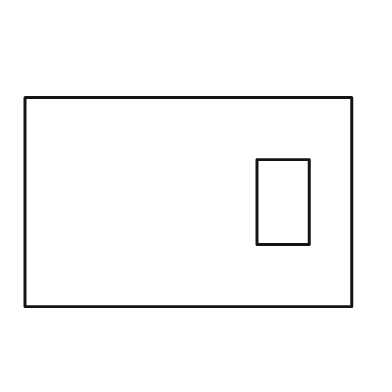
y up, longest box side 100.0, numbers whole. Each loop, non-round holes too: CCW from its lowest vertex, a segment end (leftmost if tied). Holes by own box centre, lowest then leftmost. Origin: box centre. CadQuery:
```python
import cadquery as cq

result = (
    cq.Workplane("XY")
    .moveTo(-50.0, -32.0)
    .lineTo(50.0, -32.0)
    .lineTo(50.0, 32.0)
    .lineTo(-50.0, 32.0)
    .close()
    .moveTo(21.0, -13.0)
    .lineTo(37.0, -13.0)
    .lineTo(37.0, 13.0)
    .lineTo(21.0, 13.0)
    .close()
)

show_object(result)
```